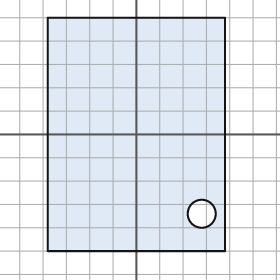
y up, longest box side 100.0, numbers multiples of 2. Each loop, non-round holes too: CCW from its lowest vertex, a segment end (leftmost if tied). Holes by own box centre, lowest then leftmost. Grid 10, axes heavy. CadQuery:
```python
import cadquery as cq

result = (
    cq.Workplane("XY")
    .moveTo(-38.0, -50.0)
    .lineTo(38.0, -50.0)
    .lineTo(38.0, 50.0)
    .lineTo(-38.0, 50.0)
    .close()
    .moveTo(28.0, -34.0)
    .circle(6.0)
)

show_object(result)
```